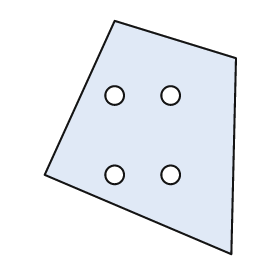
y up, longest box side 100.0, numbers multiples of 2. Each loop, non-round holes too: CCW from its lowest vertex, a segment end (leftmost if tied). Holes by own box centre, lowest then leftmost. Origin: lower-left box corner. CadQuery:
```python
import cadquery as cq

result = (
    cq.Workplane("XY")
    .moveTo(80.0, 0.0)
    .lineTo(82.0, 84.0)
    .lineTo(30.0, 100.0)
    .lineTo(0.0, 34.0)
    .close()
    .moveTo(30.0, 34.0)
    .circle(4.0)
    .moveTo(54.0, 34.0)
    .circle(4.0)
    .moveTo(30.0, 68.0)
    .circle(4.0)
    .moveTo(54.0, 68.0)
    .circle(4.0)
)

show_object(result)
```